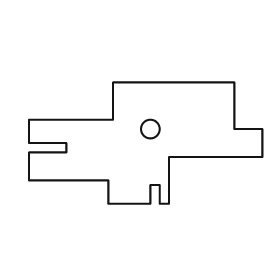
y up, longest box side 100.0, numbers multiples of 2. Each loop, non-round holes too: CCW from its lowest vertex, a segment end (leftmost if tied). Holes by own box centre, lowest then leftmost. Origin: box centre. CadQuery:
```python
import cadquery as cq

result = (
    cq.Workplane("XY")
    .moveTo(-16.0, -26.0)
    .lineTo(2.0, -26.0)
    .lineTo(2.0, -18.0)
    .lineTo(6.0, -18.0)
    .lineTo(6.0, -26.0)
    .lineTo(10.0, -26.0)
    .lineTo(10.0, -6.0)
    .lineTo(50.0, -6.0)
    .lineTo(50.0, 6.0)
    .lineTo(38.0, 6.0)
    .lineTo(38.0, 26.0)
    .lineTo(-14.0, 26.0)
    .lineTo(-14.0, 10.0)
    .lineTo(-50.0, 10.0)
    .lineTo(-50.0, 0.0)
    .lineTo(-34.0, 0.0)
    .lineTo(-34.0, -4.0)
    .lineTo(-50.0, -4.0)
    .lineTo(-50.0, -16.0)
    .lineTo(-16.0, -16.0)
    .close()
    .moveTo(2.0, 6.0)
    .circle(4.0)
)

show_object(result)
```